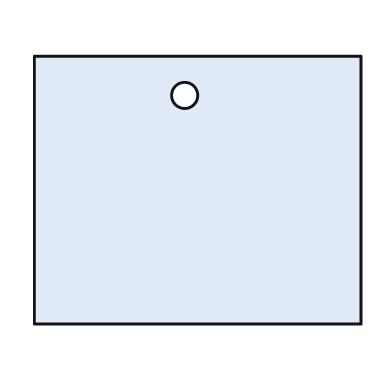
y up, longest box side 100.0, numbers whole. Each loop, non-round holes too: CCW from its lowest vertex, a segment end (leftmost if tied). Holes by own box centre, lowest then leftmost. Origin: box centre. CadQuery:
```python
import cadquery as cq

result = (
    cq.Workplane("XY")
    .moveTo(-50.0, -41.0)
    .lineTo(50.0, -41.0)
    .lineTo(50.0, 41.0)
    .lineTo(-50.0, 41.0)
    .close()
    .moveTo(-4.0, 29.0)
    .circle(4.0)
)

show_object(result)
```